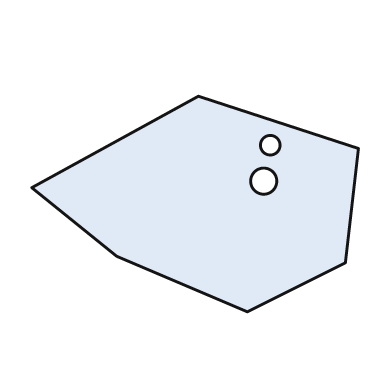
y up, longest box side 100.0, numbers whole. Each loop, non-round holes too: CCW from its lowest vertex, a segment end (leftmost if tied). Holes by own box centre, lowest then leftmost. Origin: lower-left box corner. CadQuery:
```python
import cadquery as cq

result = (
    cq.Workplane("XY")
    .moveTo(66.0, 0.0)
    .lineTo(96.0, 15.0)
    .lineTo(100.0, 50.0)
    .lineTo(51.0, 66.0)
    .lineTo(0.0, 38.0)
    .lineTo(26.0, 17.0)
    .close()
    .moveTo(71.0, 40.0)
    .circle(4.0)
    .moveTo(73.0, 51.0)
    .circle(3.0)
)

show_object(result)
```